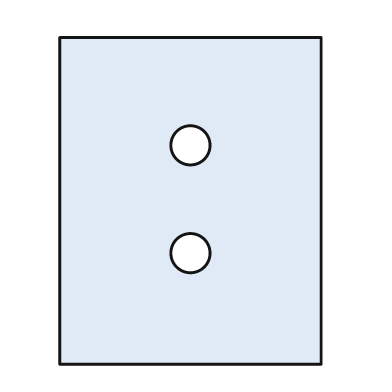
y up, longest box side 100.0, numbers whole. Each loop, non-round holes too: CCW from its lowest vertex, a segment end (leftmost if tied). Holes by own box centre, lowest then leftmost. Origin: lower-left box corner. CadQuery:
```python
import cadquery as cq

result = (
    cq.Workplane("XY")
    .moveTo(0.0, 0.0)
    .lineTo(80.0, 0.0)
    .lineTo(80.0, 100.0)
    .lineTo(0.0, 100.0)
    .close()
    .moveTo(40.0, 34.0)
    .circle(6.0)
    .moveTo(40.0, 67.0)
    .circle(6.0)
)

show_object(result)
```